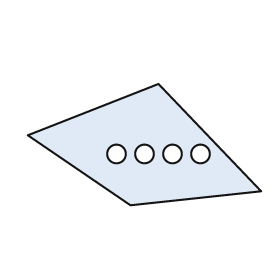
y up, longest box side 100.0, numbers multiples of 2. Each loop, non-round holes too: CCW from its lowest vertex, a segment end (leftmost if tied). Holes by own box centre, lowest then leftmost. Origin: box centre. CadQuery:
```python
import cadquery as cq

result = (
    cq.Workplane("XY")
    .moveTo(-6.0, -26.0)
    .lineTo(50.0, -20.0)
    .lineTo(6.0, 26.0)
    .lineTo(-50.0, 4.0)
    .close()
    .moveTo(-12.0, -4.0)
    .circle(4.0)
    .moveTo(0.0, -4.0)
    .circle(4.0)
    .moveTo(12.0, -4.0)
    .circle(4.0)
    .moveTo(24.0, -4.0)
    .circle(4.0)
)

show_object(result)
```